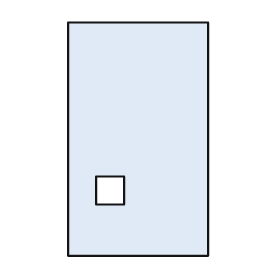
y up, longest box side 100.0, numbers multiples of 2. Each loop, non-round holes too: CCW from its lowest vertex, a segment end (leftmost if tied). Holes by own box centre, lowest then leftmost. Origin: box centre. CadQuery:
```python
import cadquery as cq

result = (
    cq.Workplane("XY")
    .moveTo(-30.0, -50.0)
    .lineTo(30.0, -50.0)
    .lineTo(30.0, 50.0)
    .lineTo(-30.0, 50.0)
    .close()
    .moveTo(-18.0, -28.0)
    .lineTo(-6.0, -28.0)
    .lineTo(-6.0, -16.0)
    .lineTo(-18.0, -16.0)
    .close()
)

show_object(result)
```